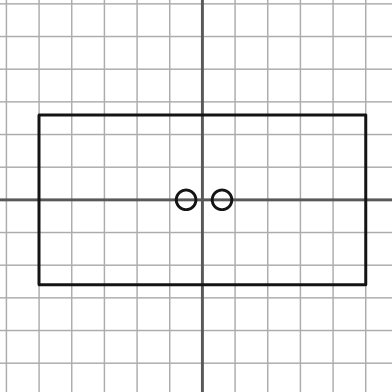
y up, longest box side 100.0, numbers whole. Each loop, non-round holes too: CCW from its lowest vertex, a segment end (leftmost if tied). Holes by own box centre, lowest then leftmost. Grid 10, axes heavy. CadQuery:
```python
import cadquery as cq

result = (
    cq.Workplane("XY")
    .moveTo(-50.0, -26.0)
    .lineTo(50.0, -26.0)
    .lineTo(50.0, 26.0)
    .lineTo(-50.0, 26.0)
    .close()
    .moveTo(-5.0, 0.0)
    .circle(3.0)
    .moveTo(6.0, 0.0)
    .circle(3.0)
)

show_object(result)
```